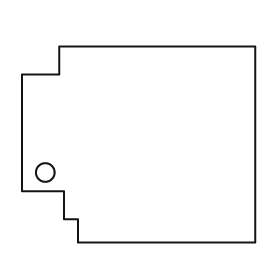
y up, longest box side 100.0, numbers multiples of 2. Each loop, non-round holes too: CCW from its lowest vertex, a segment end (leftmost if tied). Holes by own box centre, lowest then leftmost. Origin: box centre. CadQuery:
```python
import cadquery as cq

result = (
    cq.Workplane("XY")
    .moveTo(-26.0, -42.0)
    .lineTo(50.0, -42.0)
    .lineTo(50.0, 42.0)
    .lineTo(-34.0, 42.0)
    .lineTo(-34.0, 30.0)
    .lineTo(-50.0, 30.0)
    .lineTo(-50.0, -20.0)
    .lineTo(-32.0, -20.0)
    .lineTo(-32.0, -32.0)
    .lineTo(-26.0, -32.0)
    .close()
    .moveTo(-40.0, -12.0)
    .circle(4.0)
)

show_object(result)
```